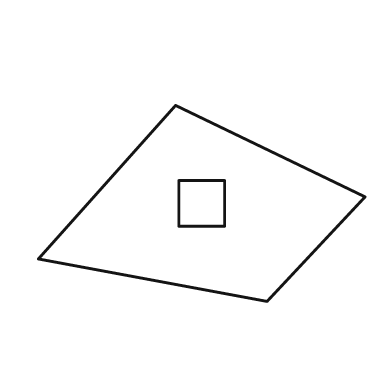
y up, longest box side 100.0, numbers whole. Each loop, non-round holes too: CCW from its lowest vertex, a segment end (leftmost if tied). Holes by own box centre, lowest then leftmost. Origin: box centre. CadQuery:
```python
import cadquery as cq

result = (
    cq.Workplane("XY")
    .moveTo(20.0, -30.0)
    .lineTo(50.0, 2.0)
    .lineTo(-8.0, 30.0)
    .lineTo(-50.0, -17.0)
    .close()
    .moveTo(-7.0, -7.0)
    .lineTo(7.0, -7.0)
    .lineTo(7.0, 7.0)
    .lineTo(-7.0, 7.0)
    .close()
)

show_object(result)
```